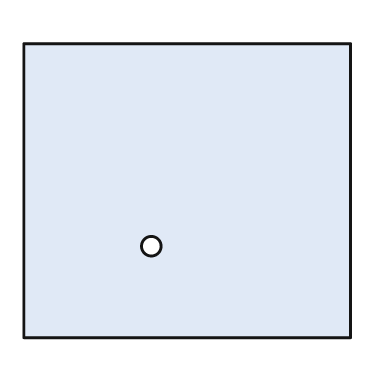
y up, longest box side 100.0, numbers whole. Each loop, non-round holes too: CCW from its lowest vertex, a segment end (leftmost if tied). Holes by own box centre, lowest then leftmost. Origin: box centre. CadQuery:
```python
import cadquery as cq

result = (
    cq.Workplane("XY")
    .moveTo(-50.0, -45.0)
    .lineTo(50.0, -45.0)
    .lineTo(50.0, 45.0)
    .lineTo(-50.0, 45.0)
    .close()
    .moveTo(-11.0, -17.0)
    .circle(3.0)
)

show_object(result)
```